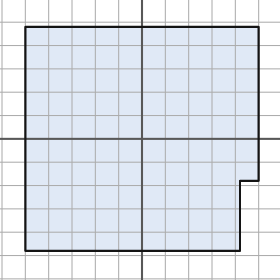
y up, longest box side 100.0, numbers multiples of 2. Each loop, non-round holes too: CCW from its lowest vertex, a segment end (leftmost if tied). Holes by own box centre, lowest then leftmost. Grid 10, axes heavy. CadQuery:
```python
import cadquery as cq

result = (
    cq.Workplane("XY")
    .moveTo(-50.0, -48.0)
    .lineTo(42.0, -48.0)
    .lineTo(42.0, -18.0)
    .lineTo(50.0, -18.0)
    .lineTo(50.0, 48.0)
    .lineTo(-50.0, 48.0)
    .close()
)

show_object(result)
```